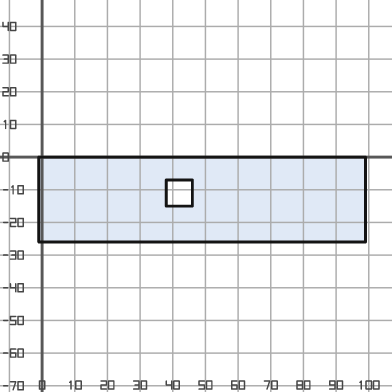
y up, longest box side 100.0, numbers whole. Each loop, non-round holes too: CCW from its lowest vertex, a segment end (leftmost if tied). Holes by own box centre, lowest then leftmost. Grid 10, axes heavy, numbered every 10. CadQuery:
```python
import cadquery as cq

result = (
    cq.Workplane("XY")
    .moveTo(-1.0, -26.0)
    .lineTo(99.0, -26.0)
    .lineTo(99.0, 0.0)
    .lineTo(-1.0, 0.0)
    .close()
    .moveTo(38.0, -15.0)
    .lineTo(46.0, -15.0)
    .lineTo(46.0, -7.0)
    .lineTo(38.0, -7.0)
    .close()
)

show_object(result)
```